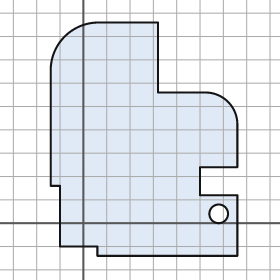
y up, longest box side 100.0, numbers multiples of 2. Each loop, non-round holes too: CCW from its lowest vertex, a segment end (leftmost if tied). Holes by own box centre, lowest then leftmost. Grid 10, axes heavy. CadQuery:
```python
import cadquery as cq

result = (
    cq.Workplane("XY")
    .moveTo(6.0, -14.0)
    .lineTo(66.0, -14.0)
    .lineTo(66.0, 12.0)
    .lineTo(50.0, 12.0)
    .lineTo(50.0, 24.0)
    .lineTo(66.0, 24.0)
    .lineTo(66.0, 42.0)
    .threePointArc((62.0, 52.0), (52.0, 56.0))
    .lineTo(32.0, 56.0)
    .lineTo(32.0, 86.0)
    .lineTo(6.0, 86.0)
    .threePointArc((-8.0, 80.0), (-14.0, 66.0))
    .lineTo(-14.0, 16.0)
    .lineTo(-10.0, 16.0)
    .lineTo(-10.0, -10.0)
    .lineTo(6.0, -10.0)
    .close()
    .moveTo(58.0, 4.0)
    .circle(4.0)
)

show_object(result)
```